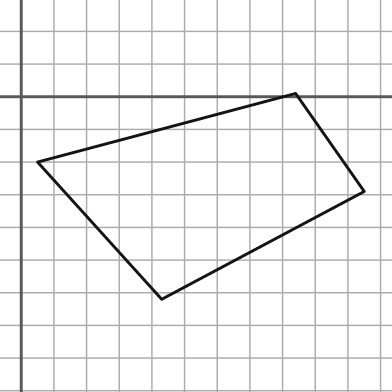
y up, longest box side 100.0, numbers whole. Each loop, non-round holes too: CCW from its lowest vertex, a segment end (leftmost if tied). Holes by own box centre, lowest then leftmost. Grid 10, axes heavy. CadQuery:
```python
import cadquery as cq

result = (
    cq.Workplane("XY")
    .moveTo(43.0, -62.0)
    .lineTo(105.0, -29.0)
    .lineTo(84.0, 1.0)
    .lineTo(5.0, -20.0)
    .close()
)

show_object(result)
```